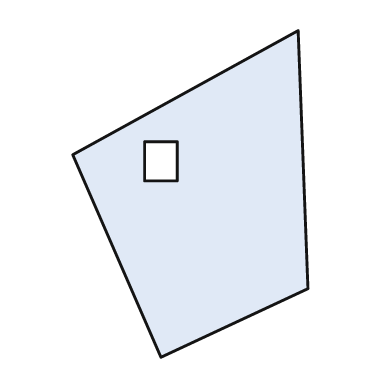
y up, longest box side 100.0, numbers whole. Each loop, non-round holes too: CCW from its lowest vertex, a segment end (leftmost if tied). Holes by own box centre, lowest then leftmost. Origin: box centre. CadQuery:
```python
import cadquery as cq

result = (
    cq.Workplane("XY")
    .moveTo(-9.0, -50.0)
    .lineTo(36.0, -29.0)
    .lineTo(33.0, 50.0)
    .lineTo(-36.0, 12.0)
    .close()
    .moveTo(-14.0, 4.0)
    .lineTo(-4.0, 4.0)
    .lineTo(-4.0, 16.0)
    .lineTo(-14.0, 16.0)
    .close()
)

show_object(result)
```